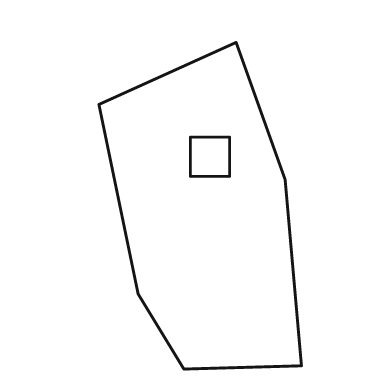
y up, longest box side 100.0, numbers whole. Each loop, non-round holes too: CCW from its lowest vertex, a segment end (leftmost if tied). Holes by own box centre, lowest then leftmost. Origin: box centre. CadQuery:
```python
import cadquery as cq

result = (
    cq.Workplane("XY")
    .moveTo(-5.0, -50.0)
    .lineTo(31.0, -49.0)
    .lineTo(26.0, 8.0)
    .lineTo(11.0, 50.0)
    .lineTo(-31.0, 31.0)
    .lineTo(-19.0, -27.0)
    .close()
    .moveTo(-3.0, 9.0)
    .lineTo(9.0, 9.0)
    .lineTo(9.0, 21.0)
    .lineTo(-3.0, 21.0)
    .close()
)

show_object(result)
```